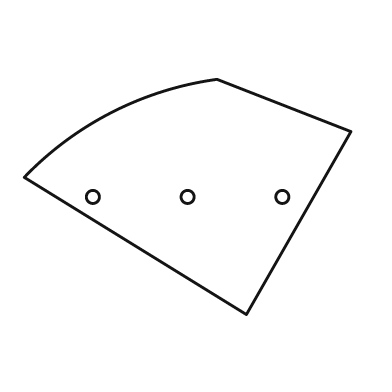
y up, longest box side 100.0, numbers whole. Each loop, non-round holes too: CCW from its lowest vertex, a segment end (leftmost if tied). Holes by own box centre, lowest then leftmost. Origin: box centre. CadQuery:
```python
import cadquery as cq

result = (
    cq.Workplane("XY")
    .moveTo(18.0, -36.0)
    .lineTo(50.0, 20.0)
    .lineTo(9.0, 36.0)
    .threePointArc((-23.0, 26.0), (-50.0, 6.0))
    .close()
    .moveTo(-29.0, 0.0)
    .circle(2.0)
    .moveTo(0.0, 0.0)
    .circle(2.0)
    .moveTo(29.0, 0.0)
    .circle(2.0)
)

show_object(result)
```